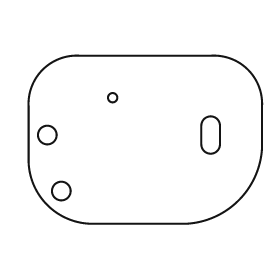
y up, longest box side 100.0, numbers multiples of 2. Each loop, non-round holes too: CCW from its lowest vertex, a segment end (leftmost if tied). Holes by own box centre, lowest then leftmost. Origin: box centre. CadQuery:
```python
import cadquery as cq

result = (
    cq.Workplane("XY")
    .moveTo(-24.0, -36.0)
    .lineTo(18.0, -36.0)
    .threePointArc((40.0, -26.0), (50.0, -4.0))
    .lineTo(50.0, 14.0)
    .threePointArc((44.0, 30.0), (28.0, 36.0))
    .lineTo(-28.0, 36.0)
    .threePointArc((-44.0, 30.0), (-50.0, 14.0))
    .lineTo(-50.0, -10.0)
    .threePointArc((-42.0, -28.0), (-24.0, -36.0))
    .close()
    .moveTo(-36.0, -22.0)
    .circle(4.0)
    .moveTo(-42.0, 2.0)
    .circle(4.0)
    .moveTo(24.0, -2.0)
    .threePointArc((28.0, -6.0), (32.0, -2.0))
    .lineTo(32.0, 6.0)
    .threePointArc((28.0, 10.0), (24.0, 6.0))
    .close()
    .moveTo(-14.0, 18.0)
    .circle(2.0)
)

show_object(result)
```